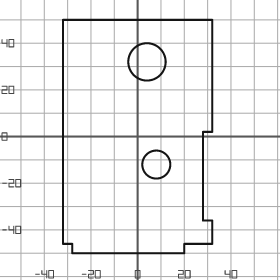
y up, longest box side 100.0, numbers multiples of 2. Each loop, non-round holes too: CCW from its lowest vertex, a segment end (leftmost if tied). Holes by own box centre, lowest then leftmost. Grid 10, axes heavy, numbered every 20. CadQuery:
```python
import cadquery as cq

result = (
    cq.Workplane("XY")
    .moveTo(-28.0, -50.0)
    .lineTo(20.0, -50.0)
    .lineTo(20.0, -46.0)
    .lineTo(32.0, -46.0)
    .lineTo(32.0, -36.0)
    .lineTo(28.0, -36.0)
    .lineTo(28.0, 2.0)
    .lineTo(32.0, 2.0)
    .lineTo(32.0, 50.0)
    .lineTo(-32.0, 50.0)
    .lineTo(-32.0, -46.0)
    .lineTo(-28.0, -46.0)
    .close()
    .moveTo(8.0, -12.0)
    .circle(6.0)
    .moveTo(4.0, 32.0)
    .circle(8.0)
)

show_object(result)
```